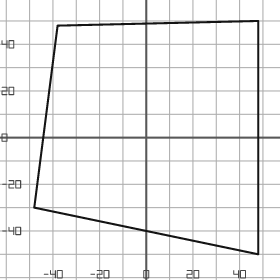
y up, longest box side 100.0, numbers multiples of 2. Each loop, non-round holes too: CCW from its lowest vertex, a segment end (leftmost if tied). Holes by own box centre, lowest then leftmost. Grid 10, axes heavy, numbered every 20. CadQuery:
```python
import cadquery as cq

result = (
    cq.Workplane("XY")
    .moveTo(48.0, -50.0)
    .lineTo(48.0, 50.0)
    .lineTo(-38.0, 48.0)
    .lineTo(-48.0, -30.0)
    .close()
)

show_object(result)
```